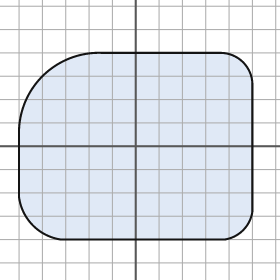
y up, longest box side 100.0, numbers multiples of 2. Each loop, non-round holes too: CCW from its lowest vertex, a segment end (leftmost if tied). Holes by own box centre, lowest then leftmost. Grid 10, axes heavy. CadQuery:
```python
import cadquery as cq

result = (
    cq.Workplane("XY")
    .moveTo(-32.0, -40.0)
    .lineTo(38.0, -40.0)
    .threePointArc((46.0, -36.0), (50.0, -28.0))
    .lineTo(50.0, 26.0)
    .threePointArc((46.0, 36.0), (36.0, 40.0))
    .lineTo(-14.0, 40.0)
    .threePointArc((-40.0, 30.0), (-50.0, 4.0))
    .lineTo(-50.0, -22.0)
    .threePointArc((-44.0, -34.0), (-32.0, -40.0))
    .close()
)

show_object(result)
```